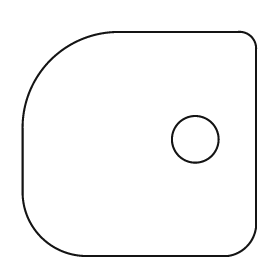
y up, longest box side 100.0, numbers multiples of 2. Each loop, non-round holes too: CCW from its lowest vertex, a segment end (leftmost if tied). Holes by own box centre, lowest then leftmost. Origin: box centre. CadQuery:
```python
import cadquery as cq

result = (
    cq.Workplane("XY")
    .moveTo(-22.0, -48.0)
    .lineTo(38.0, -48.0)
    .threePointArc((46.0, -44.0), (50.0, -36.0))
    .lineTo(50.0, 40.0)
    .threePointArc((48.0, 46.0), (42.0, 48.0))
    .lineTo(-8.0, 48.0)
    .threePointArc((-38.0, 36.0), (-50.0, 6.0))
    .lineTo(-50.0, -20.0)
    .threePointArc((-42.0, -40.0), (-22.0, -48.0))
    .close()
    .moveTo(24.0, 2.0)
    .circle(10.0)
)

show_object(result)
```